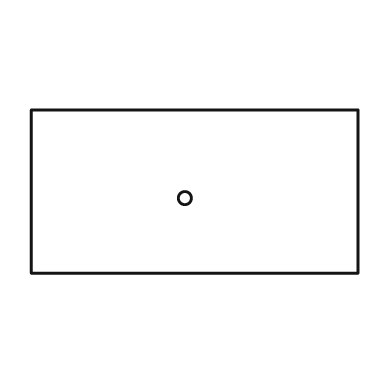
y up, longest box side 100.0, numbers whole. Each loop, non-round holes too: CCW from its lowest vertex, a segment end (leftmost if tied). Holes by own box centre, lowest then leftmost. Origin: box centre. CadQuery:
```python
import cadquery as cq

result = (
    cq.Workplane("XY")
    .moveTo(-50.0, -25.0)
    .lineTo(50.0, -25.0)
    .lineTo(50.0, 25.0)
    .lineTo(-50.0, 25.0)
    .close()
    .moveTo(-3.0, -2.0)
    .circle(2.0)
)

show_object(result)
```